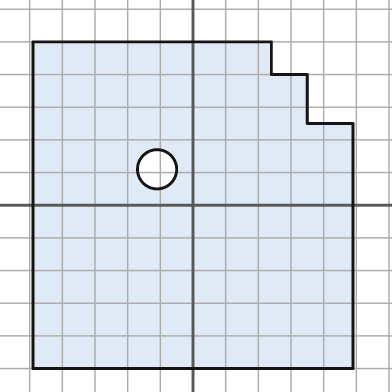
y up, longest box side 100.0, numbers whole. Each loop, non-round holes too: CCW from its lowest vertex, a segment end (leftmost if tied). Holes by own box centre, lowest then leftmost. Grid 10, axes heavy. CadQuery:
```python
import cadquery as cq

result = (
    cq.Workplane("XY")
    .moveTo(-49.0, -50.0)
    .lineTo(49.0, -50.0)
    .lineTo(49.0, 25.0)
    .lineTo(35.0, 25.0)
    .lineTo(35.0, 40.0)
    .lineTo(24.0, 40.0)
    .lineTo(24.0, 50.0)
    .lineTo(-49.0, 50.0)
    .close()
    .moveTo(-11.0, 11.0)
    .circle(6.0)
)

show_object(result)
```